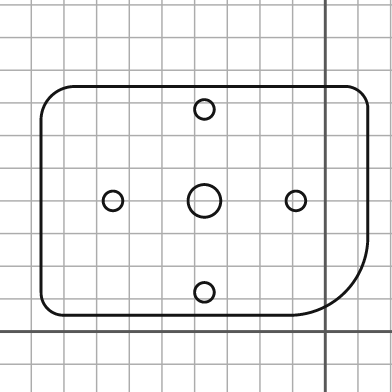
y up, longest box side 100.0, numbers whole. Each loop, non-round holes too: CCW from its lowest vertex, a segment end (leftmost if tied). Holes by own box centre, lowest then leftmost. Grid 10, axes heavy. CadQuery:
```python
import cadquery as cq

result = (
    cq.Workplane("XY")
    .moveTo(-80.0, 5.0)
    .lineTo(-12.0, 5.0)
    .threePointArc((6.0, 12.0), (13.0, 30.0))
    .lineTo(13.0, 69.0)
    .threePointArc((11.0, 73.0), (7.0, 75.0))
    .lineTo(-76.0, 75.0)
    .threePointArc((-84.0, 72.0), (-87.0, 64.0))
    .lineTo(-87.0, 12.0)
    .threePointArc((-85.0, 7.0), (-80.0, 5.0))
    .close()
    .moveTo(-37.0, 12.0)
    .circle(3.0)
    .moveTo(-65.0, 40.0)
    .circle(3.0)
    .moveTo(-37.0, 40.0)
    .circle(5.0)
    .moveTo(-9.0, 40.0)
    .circle(3.0)
    .moveTo(-37.0, 68.0)
    .circle(3.0)
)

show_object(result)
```